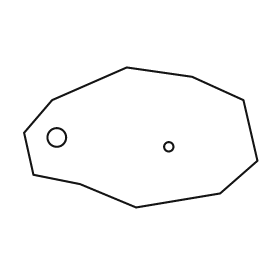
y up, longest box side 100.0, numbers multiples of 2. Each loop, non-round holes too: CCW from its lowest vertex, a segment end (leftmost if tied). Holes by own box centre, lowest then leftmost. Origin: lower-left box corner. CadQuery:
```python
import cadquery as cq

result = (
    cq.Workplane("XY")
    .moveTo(48.0, 0.0)
    .lineTo(84.0, 6.0)
    .lineTo(100.0, 20.0)
    .lineTo(94.0, 46.0)
    .lineTo(72.0, 56.0)
    .lineTo(44.0, 60.0)
    .lineTo(12.0, 46.0)
    .lineTo(0.0, 32.0)
    .lineTo(4.0, 14.0)
    .lineTo(24.0, 10.0)
    .close()
    .moveTo(62.0, 26.0)
    .circle(2.0)
    .moveTo(14.0, 30.0)
    .circle(4.0)
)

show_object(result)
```